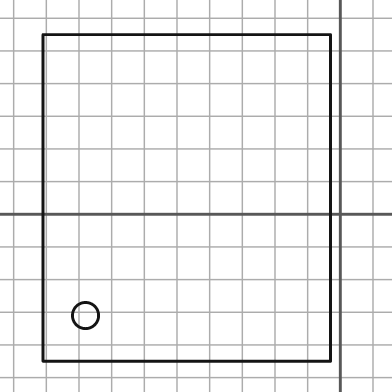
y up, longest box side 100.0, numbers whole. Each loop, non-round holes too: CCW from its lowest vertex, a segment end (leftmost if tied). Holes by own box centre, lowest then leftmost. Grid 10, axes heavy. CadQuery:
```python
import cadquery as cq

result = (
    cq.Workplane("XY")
    .moveTo(-91.0, -45.0)
    .lineTo(-3.0, -45.0)
    .lineTo(-3.0, 55.0)
    .lineTo(-91.0, 55.0)
    .close()
    .moveTo(-78.0, -31.0)
    .circle(4.0)
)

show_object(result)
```